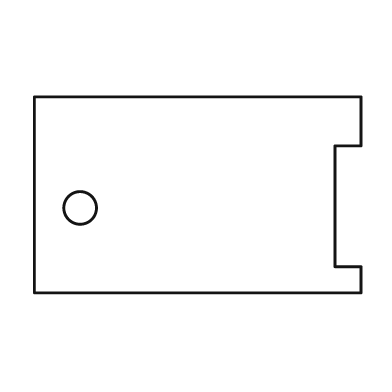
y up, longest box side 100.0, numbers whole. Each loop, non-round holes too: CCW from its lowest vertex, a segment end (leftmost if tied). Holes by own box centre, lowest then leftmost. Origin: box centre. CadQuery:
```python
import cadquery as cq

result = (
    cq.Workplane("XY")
    .moveTo(-50.0, -30.0)
    .lineTo(50.0, -30.0)
    .lineTo(50.0, -22.0)
    .lineTo(42.0, -22.0)
    .lineTo(42.0, 15.0)
    .lineTo(50.0, 15.0)
    .lineTo(50.0, 30.0)
    .lineTo(-50.0, 30.0)
    .close()
    .moveTo(-36.0, -4.0)
    .circle(5.0)
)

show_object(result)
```